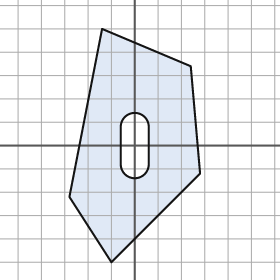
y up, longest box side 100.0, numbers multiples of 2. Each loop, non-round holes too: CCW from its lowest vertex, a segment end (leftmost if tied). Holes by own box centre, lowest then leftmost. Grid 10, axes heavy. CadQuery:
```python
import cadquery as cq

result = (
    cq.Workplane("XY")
    .moveTo(-10.0, -50.0)
    .lineTo(28.0, -12.0)
    .lineTo(24.0, 34.0)
    .lineTo(-14.0, 50.0)
    .lineTo(-28.0, -22.0)
    .close()
    .moveTo(-6.0, -8.0)
    .threePointArc((0.0, -14.0), (6.0, -8.0))
    .lineTo(6.0, 8.0)
    .threePointArc((0.0, 14.0), (-6.0, 8.0))
    .close()
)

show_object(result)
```